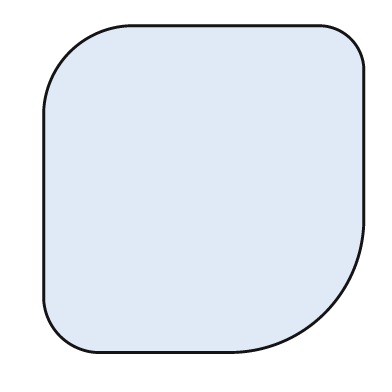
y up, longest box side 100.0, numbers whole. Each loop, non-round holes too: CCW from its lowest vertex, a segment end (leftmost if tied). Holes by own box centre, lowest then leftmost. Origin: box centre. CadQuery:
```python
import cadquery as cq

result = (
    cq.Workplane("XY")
    .moveTo(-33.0, -50.0)
    .lineTo(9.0, -50.0)
    .threePointArc((37.0, -38.0), (49.0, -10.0))
    .lineTo(49.0, 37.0)
    .threePointArc((45.0, 46.0), (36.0, 50.0))
    .lineTo(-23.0, 50.0)
    .threePointArc((-41.0, 42.0), (-49.0, 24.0))
    .lineTo(-49.0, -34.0)
    .threePointArc((-44.0, -45.0), (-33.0, -50.0))
    .close()
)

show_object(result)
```